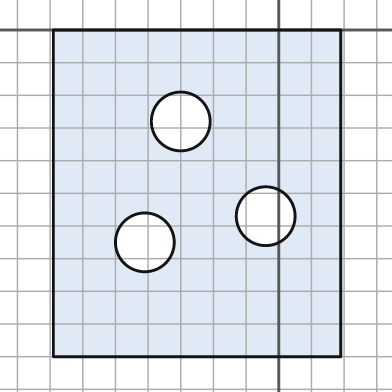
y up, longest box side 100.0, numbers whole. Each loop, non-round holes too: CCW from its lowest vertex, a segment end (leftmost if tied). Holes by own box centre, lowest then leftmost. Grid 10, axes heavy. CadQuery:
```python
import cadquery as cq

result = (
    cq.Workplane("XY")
    .moveTo(-69.0, -100.0)
    .lineTo(19.0, -100.0)
    .lineTo(19.0, 0.0)
    .lineTo(-69.0, 0.0)
    .close()
    .moveTo(-41.0, -65.0)
    .circle(9.0)
    .moveTo(-4.0, -57.0)
    .circle(9.0)
    .moveTo(-30.0, -28.0)
    .circle(9.0)
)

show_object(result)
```